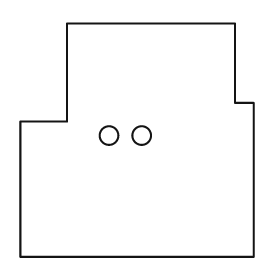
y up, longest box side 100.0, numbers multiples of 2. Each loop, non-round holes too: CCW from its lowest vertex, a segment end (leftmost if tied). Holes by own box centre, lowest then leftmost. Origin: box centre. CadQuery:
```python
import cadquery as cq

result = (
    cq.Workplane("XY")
    .moveTo(-50.0, -50.0)
    .lineTo(50.0, -50.0)
    .lineTo(50.0, 16.0)
    .lineTo(42.0, 16.0)
    .lineTo(42.0, 50.0)
    .lineTo(-30.0, 50.0)
    .lineTo(-30.0, 8.0)
    .lineTo(-50.0, 8.0)
    .close()
    .moveTo(-12.0, 2.0)
    .circle(4.0)
    .moveTo(2.0, 2.0)
    .circle(4.0)
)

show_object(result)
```